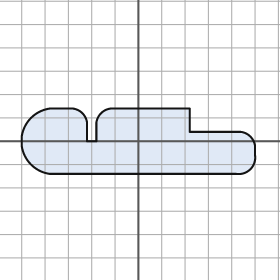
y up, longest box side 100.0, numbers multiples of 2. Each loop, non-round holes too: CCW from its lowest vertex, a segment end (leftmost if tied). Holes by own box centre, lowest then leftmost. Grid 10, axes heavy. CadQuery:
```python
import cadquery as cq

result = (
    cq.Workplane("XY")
    .moveTo(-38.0, -14.0)
    .lineTo(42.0, -14.0)
    .threePointArc((48.0, -12.0), (50.0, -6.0))
    .lineTo(50.0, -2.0)
    .threePointArc((48.0, 2.0), (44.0, 4.0))
    .lineTo(22.0, 4.0)
    .lineTo(22.0, 14.0)
    .lineTo(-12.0, 14.0)
    .threePointArc((-16.0, 12.0), (-18.0, 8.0))
    .lineTo(-18.0, 0.0)
    .lineTo(-22.0, 0.0)
    .lineTo(-22.0, 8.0)
    .threePointArc((-24.0, 12.0), (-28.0, 14.0))
    .lineTo(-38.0, 14.0)
    .threePointArc((-46.0, 10.0), (-50.0, 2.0))
    .lineTo(-50.0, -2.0)
    .threePointArc((-46.0, -10.0), (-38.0, -14.0))
    .close()
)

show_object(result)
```